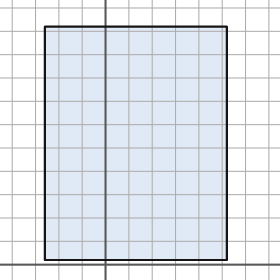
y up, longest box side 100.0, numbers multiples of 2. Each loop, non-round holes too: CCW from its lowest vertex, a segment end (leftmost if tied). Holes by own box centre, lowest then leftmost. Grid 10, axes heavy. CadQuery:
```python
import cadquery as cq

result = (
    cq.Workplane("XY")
    .moveTo(-26.0, 2.0)
    .lineTo(52.0, 2.0)
    .lineTo(52.0, 102.0)
    .lineTo(-26.0, 102.0)
    .close()
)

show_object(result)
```